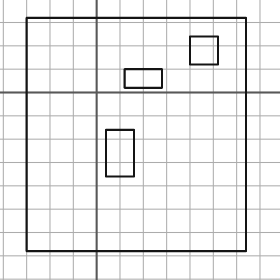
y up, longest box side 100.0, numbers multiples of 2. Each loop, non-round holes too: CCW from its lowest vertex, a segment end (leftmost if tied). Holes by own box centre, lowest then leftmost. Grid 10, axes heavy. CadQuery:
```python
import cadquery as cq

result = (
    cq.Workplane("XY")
    .moveTo(-30.0, -68.0)
    .lineTo(64.0, -68.0)
    .lineTo(64.0, 32.0)
    .lineTo(-30.0, 32.0)
    .close()
    .moveTo(4.0, -36.0)
    .lineTo(16.0, -36.0)
    .lineTo(16.0, -16.0)
    .lineTo(4.0, -16.0)
    .close()
    .moveTo(12.0, 2.0)
    .lineTo(28.0, 2.0)
    .lineTo(28.0, 10.0)
    .lineTo(12.0, 10.0)
    .close()
    .moveTo(40.0, 12.0)
    .lineTo(52.0, 12.0)
    .lineTo(52.0, 24.0)
    .lineTo(40.0, 24.0)
    .close()
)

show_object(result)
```